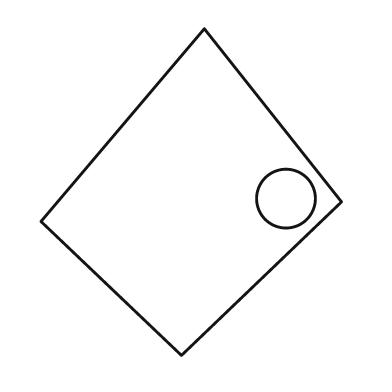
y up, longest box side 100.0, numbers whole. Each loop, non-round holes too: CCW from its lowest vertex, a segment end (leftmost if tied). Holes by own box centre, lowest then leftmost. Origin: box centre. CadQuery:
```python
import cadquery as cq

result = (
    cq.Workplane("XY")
    .moveTo(-3.0, -50.0)
    .lineTo(46.0, -3.0)
    .lineTo(4.0, 50.0)
    .lineTo(-46.0, -9.0)
    .close()
    .moveTo(29.0, -2.0)
    .circle(9.0)
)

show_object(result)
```